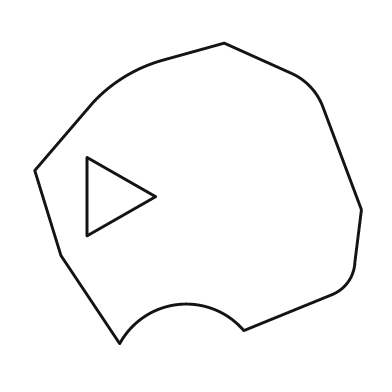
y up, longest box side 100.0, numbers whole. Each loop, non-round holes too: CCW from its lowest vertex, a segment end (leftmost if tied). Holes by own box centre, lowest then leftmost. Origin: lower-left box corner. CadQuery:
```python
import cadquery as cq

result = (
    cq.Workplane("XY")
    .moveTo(26.0, 0.0)
    .threePointArc((44.0, 12.0), (64.0, 4.0))
    .lineTo(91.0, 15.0)
    .threePointArc((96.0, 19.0), (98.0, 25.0))
    .lineTo(100.0, 41.0)
    .lineTo(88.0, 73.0)
    .threePointArc((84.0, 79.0), (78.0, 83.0))
    .lineTo(58.0, 92.0)
    .lineTo(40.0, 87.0)
    .threePointArc((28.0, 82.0), (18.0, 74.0))
    .lineTo(0.0, 53.0)
    .lineTo(8.0, 27.0)
    .close()
    .moveTo(16.0, 33.0)
    .lineTo(37.0, 45.0)
    .lineTo(16.0, 57.0)
    .close()
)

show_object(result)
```